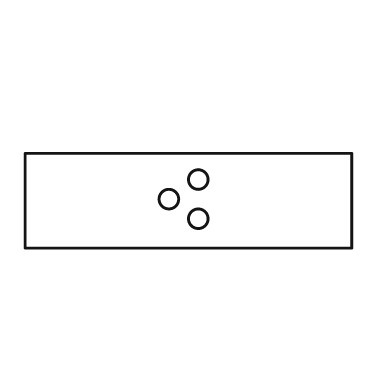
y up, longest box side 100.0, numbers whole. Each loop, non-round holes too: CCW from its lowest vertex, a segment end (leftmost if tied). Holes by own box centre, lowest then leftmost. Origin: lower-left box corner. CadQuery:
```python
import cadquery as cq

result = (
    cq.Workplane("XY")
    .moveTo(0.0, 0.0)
    .lineTo(100.0, 0.0)
    .lineTo(100.0, 29.0)
    .lineTo(0.0, 29.0)
    .close()
    .moveTo(53.0, 9.0)
    .circle(3.0)
    .moveTo(44.0, 15.0)
    .circle(3.0)
    .moveTo(53.0, 21.0)
    .circle(3.0)
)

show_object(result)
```